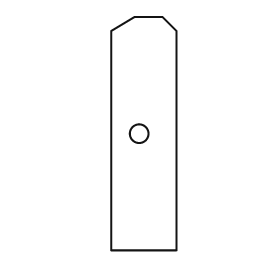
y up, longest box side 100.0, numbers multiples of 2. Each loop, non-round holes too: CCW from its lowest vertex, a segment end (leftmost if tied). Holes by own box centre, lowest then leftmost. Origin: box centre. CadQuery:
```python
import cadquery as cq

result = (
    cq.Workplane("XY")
    .moveTo(-14.0, -50.0)
    .lineTo(14.0, -50.0)
    .lineTo(14.0, 44.0)
    .lineTo(8.0, 50.0)
    .lineTo(-4.0, 50.0)
    .lineTo(-14.0, 44.0)
    .close()
    .moveTo(-2.0, 0.0)
    .circle(4.0)
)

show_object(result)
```